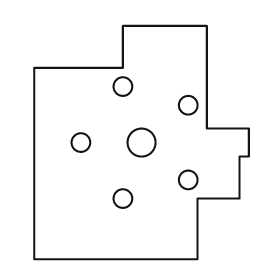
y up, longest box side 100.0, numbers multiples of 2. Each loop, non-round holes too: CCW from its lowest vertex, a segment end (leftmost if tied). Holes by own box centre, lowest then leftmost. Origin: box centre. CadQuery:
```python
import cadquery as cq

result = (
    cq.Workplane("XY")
    .moveTo(-46.0, -50.0)
    .lineTo(24.0, -50.0)
    .lineTo(24.0, -24.0)
    .lineTo(42.0, -24.0)
    .lineTo(42.0, -6.0)
    .lineTo(46.0, -6.0)
    .lineTo(46.0, 6.0)
    .lineTo(28.0, 6.0)
    .lineTo(28.0, 50.0)
    .lineTo(-8.0, 50.0)
    .lineTo(-8.0, 32.0)
    .lineTo(-46.0, 32.0)
    .close()
    .moveTo(-8.0, -24.0)
    .circle(4.0)
    .moveTo(20.0, -16.0)
    .circle(4.0)
    .moveTo(-26.0, 0.0)
    .circle(4.0)
    .moveTo(0.0, 0.0)
    .circle(6.0)
    .moveTo(20.0, 16.0)
    .circle(4.0)
    .moveTo(-8.0, 24.0)
    .circle(4.0)
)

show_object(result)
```